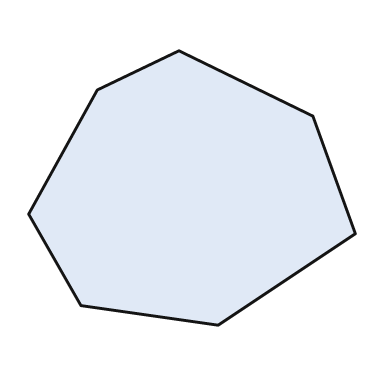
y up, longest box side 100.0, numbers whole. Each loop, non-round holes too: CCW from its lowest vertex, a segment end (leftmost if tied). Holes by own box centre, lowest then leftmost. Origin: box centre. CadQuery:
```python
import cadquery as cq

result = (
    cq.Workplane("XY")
    .moveTo(8.0, -42.0)
    .lineTo(50.0, -14.0)
    .lineTo(37.0, 22.0)
    .lineTo(-4.0, 42.0)
    .lineTo(-29.0, 30.0)
    .lineTo(-50.0, -8.0)
    .lineTo(-34.0, -36.0)
    .close()
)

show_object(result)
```